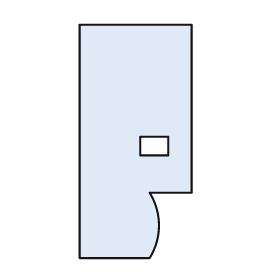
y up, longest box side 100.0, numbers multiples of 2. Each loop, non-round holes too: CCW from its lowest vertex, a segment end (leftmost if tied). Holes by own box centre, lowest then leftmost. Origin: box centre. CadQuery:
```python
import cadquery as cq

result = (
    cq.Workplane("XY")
    .moveTo(-24.0, -50.0)
    .lineTo(6.0, -50.0)
    .threePointArc((10.0, -36.0), (6.0, -22.0))
    .lineTo(24.0, -22.0)
    .lineTo(24.0, 50.0)
    .lineTo(-24.0, 50.0)
    .close()
    .moveTo(2.0, -6.0)
    .lineTo(14.0, -6.0)
    .lineTo(14.0, 2.0)
    .lineTo(2.0, 2.0)
    .close()
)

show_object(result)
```